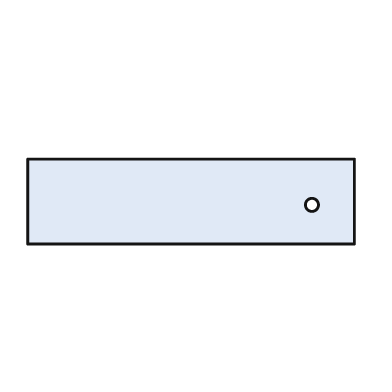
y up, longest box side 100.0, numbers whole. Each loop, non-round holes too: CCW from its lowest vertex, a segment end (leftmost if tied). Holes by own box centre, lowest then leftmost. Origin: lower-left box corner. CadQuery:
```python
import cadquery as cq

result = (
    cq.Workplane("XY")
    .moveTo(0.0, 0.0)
    .lineTo(100.0, 0.0)
    .lineTo(100.0, 26.0)
    .lineTo(0.0, 26.0)
    .close()
    .moveTo(87.0, 12.0)
    .circle(2.0)
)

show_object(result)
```